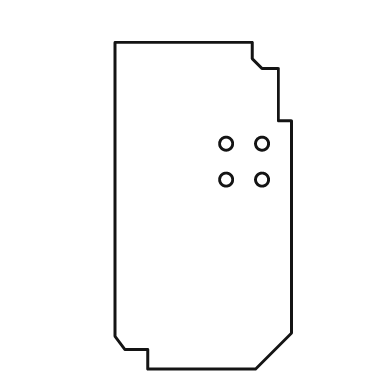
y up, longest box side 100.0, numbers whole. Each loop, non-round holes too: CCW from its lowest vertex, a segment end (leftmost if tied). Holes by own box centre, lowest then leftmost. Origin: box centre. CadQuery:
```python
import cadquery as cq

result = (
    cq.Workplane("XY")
    .moveTo(-17.0, -50.0)
    .lineTo(16.0, -50.0)
    .lineTo(27.0, -39.0)
    .lineTo(27.0, 26.0)
    .lineTo(23.0, 26.0)
    .lineTo(23.0, 42.0)
    .lineTo(18.0, 42.0)
    .lineTo(15.0, 45.0)
    .lineTo(15.0, 50.0)
    .lineTo(-27.0, 50.0)
    .lineTo(-27.0, -40.0)
    .lineTo(-24.0, -44.0)
    .lineTo(-17.0, -44.0)
    .close()
    .moveTo(7.0, 8.0)
    .circle(2.0)
    .moveTo(18.0, 8.0)
    .circle(2.0)
    .moveTo(7.0, 19.0)
    .circle(2.0)
    .moveTo(18.0, 19.0)
    .circle(2.0)
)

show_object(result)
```